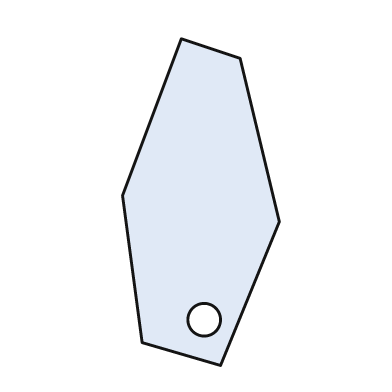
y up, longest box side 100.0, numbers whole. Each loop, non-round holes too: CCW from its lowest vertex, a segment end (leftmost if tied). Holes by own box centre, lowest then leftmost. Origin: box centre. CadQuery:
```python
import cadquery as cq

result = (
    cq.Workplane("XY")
    .moveTo(6.0, -50.0)
    .lineTo(24.0, -6.0)
    .lineTo(12.0, 44.0)
    .lineTo(-6.0, 50.0)
    .lineTo(-24.0, 2.0)
    .lineTo(-18.0, -43.0)
    .close()
    .moveTo(1.0, -36.0)
    .circle(5.0)
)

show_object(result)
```